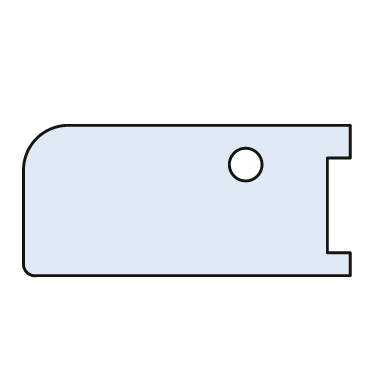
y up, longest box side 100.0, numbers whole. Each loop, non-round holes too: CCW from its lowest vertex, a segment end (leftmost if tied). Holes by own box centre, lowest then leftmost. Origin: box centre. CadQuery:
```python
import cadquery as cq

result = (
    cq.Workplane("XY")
    .moveTo(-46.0, -23.0)
    .lineTo(50.0, -23.0)
    .lineTo(50.0, -16.0)
    .lineTo(43.0, -16.0)
    .lineTo(43.0, 13.0)
    .lineTo(50.0, 13.0)
    .lineTo(50.0, 23.0)
    .lineTo(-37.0, 23.0)
    .threePointArc((-46.0, 19.0), (-50.0, 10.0))
    .lineTo(-50.0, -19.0)
    .threePointArc((-49.0, -22.0), (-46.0, -23.0))
    .close()
    .moveTo(18.0, 11.0)
    .circle(5.0)
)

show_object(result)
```